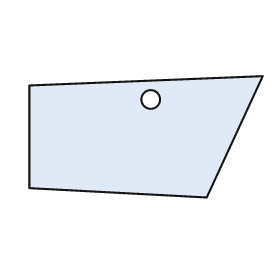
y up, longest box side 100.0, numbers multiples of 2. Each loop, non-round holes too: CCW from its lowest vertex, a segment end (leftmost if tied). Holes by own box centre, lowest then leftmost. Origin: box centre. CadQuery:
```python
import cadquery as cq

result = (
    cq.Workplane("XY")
    .moveTo(26.0, -26.0)
    .lineTo(50.0, 26.0)
    .lineTo(-50.0, 22.0)
    .lineTo(-50.0, -22.0)
    .close()
    .moveTo(2.0, 16.0)
    .circle(4.0)
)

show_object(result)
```